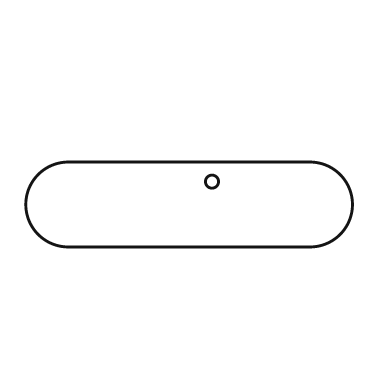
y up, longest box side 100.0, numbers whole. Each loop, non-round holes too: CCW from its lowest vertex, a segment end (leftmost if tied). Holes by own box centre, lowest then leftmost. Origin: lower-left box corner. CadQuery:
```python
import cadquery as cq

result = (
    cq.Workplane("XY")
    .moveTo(13.0, 0.0)
    .lineTo(87.0, 0.0)
    .threePointArc((100.0, 13.0), (87.0, 26.0))
    .lineTo(13.0, 26.0)
    .threePointArc((0.0, 13.0), (13.0, 0.0))
    .close()
    .moveTo(57.0, 20.0)
    .circle(2.0)
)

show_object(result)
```